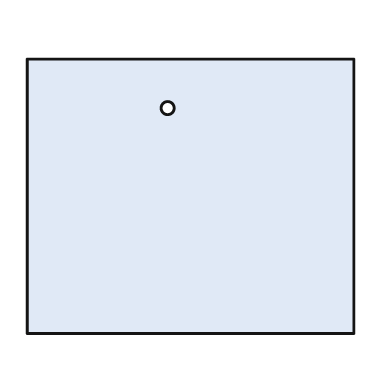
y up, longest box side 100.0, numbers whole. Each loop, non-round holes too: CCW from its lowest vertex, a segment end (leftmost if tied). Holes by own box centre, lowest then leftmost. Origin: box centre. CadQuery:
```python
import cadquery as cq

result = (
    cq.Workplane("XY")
    .moveTo(-50.0, -42.0)
    .lineTo(50.0, -42.0)
    .lineTo(50.0, 42.0)
    .lineTo(-50.0, 42.0)
    .close()
    .moveTo(-7.0, 27.0)
    .circle(2.0)
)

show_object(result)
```